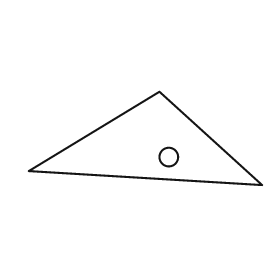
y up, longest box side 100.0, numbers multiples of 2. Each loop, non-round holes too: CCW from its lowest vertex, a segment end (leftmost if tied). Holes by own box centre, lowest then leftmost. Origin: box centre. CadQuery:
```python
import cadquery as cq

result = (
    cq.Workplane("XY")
    .moveTo(50.0, -20.0)
    .lineTo(6.0, 20.0)
    .lineTo(-50.0, -14.0)
    .close()
    .moveTo(10.0, -8.0)
    .circle(4.0)
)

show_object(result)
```